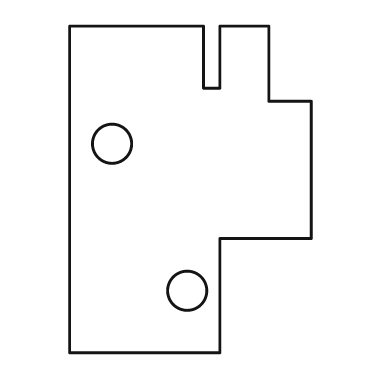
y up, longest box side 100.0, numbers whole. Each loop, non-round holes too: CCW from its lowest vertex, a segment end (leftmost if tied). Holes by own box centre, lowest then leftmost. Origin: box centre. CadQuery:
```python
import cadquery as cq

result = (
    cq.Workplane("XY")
    .moveTo(-37.0, -50.0)
    .lineTo(9.0, -50.0)
    .lineTo(9.0, -15.0)
    .lineTo(37.0, -15.0)
    .lineTo(37.0, 27.0)
    .lineTo(24.0, 27.0)
    .lineTo(24.0, 50.0)
    .lineTo(9.0, 50.0)
    .lineTo(9.0, 31.0)
    .lineTo(4.0, 31.0)
    .lineTo(4.0, 50.0)
    .lineTo(-37.0, 50.0)
    .close()
    .moveTo(-1.0, -31.0)
    .circle(6.0)
    .moveTo(-24.0, 14.0)
    .circle(6.0)
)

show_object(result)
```